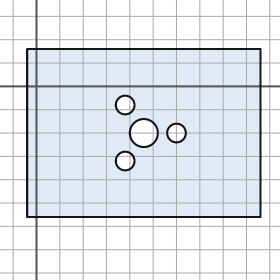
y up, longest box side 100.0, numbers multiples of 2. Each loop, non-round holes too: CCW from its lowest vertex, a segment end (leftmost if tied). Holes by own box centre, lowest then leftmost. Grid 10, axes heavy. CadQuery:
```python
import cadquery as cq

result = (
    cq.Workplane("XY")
    .moveTo(-4.0, -56.0)
    .lineTo(96.0, -56.0)
    .lineTo(96.0, 16.0)
    .lineTo(-4.0, 16.0)
    .close()
    .moveTo(38.0, -32.0)
    .circle(4.0)
    .moveTo(46.0, -20.0)
    .circle(6.0)
    .moveTo(60.0, -20.0)
    .circle(4.0)
    .moveTo(38.0, -8.0)
    .circle(4.0)
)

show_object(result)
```